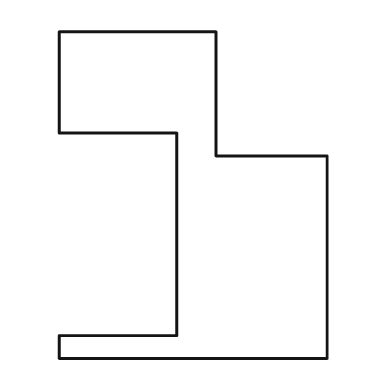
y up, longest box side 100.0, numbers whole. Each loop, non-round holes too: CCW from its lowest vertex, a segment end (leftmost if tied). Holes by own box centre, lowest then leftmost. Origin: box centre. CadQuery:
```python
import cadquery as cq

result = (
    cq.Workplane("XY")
    .moveTo(-41.0, -50.0)
    .lineTo(41.0, -50.0)
    .lineTo(41.0, 12.0)
    .lineTo(7.0, 12.0)
    .lineTo(7.0, 50.0)
    .lineTo(-41.0, 50.0)
    .lineTo(-41.0, 19.0)
    .lineTo(-5.0, 19.0)
    .lineTo(-5.0, -43.0)
    .lineTo(-41.0, -43.0)
    .close()
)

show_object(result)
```